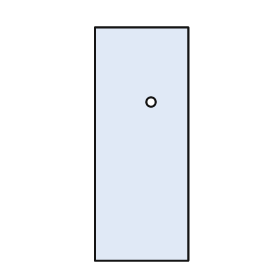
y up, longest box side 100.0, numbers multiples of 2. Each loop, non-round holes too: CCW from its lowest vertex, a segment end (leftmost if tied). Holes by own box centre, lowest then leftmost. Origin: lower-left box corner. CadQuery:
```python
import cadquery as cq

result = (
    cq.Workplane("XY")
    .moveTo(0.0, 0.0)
    .lineTo(40.0, 0.0)
    .lineTo(40.0, 100.0)
    .lineTo(0.0, 100.0)
    .close()
    .moveTo(24.0, 68.0)
    .circle(2.0)
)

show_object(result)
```